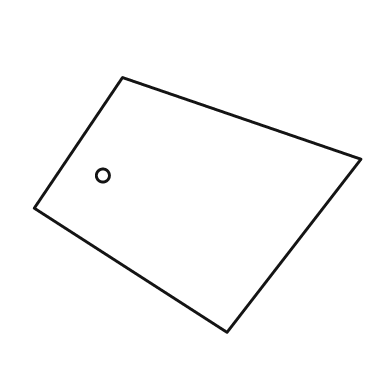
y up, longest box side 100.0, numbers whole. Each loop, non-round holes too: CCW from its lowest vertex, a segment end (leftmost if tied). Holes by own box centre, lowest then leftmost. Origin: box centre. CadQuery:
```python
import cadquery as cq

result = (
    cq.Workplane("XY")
    .moveTo(9.0, -39.0)
    .lineTo(50.0, 14.0)
    .lineTo(-23.0, 39.0)
    .lineTo(-50.0, -1.0)
    .close()
    .moveTo(-29.0, 9.0)
    .circle(2.0)
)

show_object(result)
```